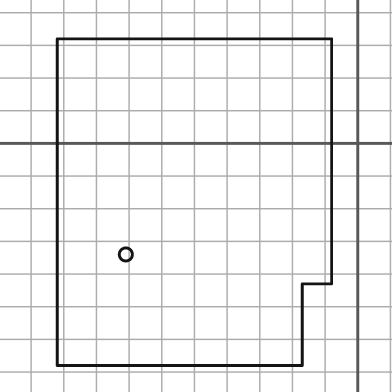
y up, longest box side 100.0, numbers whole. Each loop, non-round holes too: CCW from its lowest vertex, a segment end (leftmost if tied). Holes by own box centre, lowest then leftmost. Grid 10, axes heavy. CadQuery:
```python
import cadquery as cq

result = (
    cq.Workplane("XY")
    .moveTo(-92.0, -68.0)
    .lineTo(-17.0, -68.0)
    .lineTo(-17.0, -43.0)
    .lineTo(-8.0, -43.0)
    .lineTo(-8.0, 32.0)
    .lineTo(-92.0, 32.0)
    .close()
    .moveTo(-71.0, -34.0)
    .circle(2.0)
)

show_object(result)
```